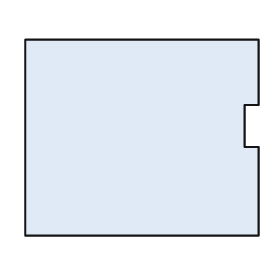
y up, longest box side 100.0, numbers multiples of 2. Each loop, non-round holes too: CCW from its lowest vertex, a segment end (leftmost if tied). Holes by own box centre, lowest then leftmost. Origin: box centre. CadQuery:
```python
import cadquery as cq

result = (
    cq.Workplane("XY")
    .moveTo(-50.0, -42.0)
    .lineTo(50.0, -42.0)
    .lineTo(50.0, -4.0)
    .lineTo(44.0, -4.0)
    .lineTo(44.0, 14.0)
    .lineTo(50.0, 14.0)
    .lineTo(50.0, 42.0)
    .lineTo(-50.0, 42.0)
    .close()
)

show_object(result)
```